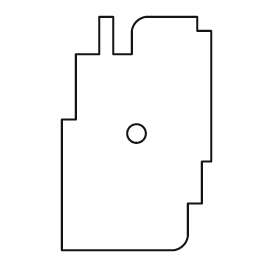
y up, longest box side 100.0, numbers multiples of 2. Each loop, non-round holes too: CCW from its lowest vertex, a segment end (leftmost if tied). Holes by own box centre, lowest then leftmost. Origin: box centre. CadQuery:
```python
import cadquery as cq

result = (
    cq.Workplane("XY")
    .moveTo(-32.0, -50.0)
    .lineTo(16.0, -50.0)
    .threePointArc((20.0, -48.0), (22.0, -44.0))
    .lineTo(22.0, -30.0)
    .lineTo(28.0, -30.0)
    .lineTo(28.0, -12.0)
    .lineTo(32.0, -12.0)
    .lineTo(32.0, 44.0)
    .lineTo(26.0, 44.0)
    .lineTo(26.0, 50.0)
    .lineTo(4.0, 50.0)
    .threePointArc((0.0, 48.0), (-2.0, 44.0))
    .lineTo(-2.0, 34.0)
    .lineTo(-10.0, 34.0)
    .lineTo(-10.0, 50.0)
    .lineTo(-16.0, 50.0)
    .lineTo(-16.0, 34.0)
    .lineTo(-26.0, 34.0)
    .lineTo(-26.0, 6.0)
    .lineTo(-32.0, 6.0)
    .close()
    .moveTo(0.0, 0.0)
    .circle(4.0)
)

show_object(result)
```